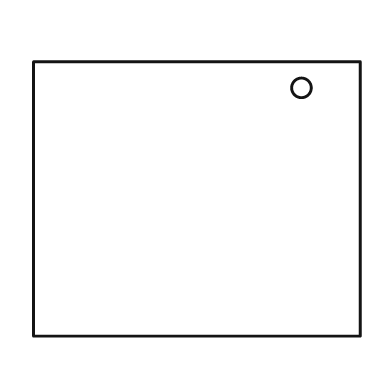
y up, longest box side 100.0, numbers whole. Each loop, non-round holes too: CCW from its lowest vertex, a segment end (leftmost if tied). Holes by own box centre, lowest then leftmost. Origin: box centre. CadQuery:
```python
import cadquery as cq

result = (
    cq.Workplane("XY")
    .moveTo(-50.0, -42.0)
    .lineTo(50.0, -42.0)
    .lineTo(50.0, 42.0)
    .lineTo(-50.0, 42.0)
    .close()
    .moveTo(32.0, 34.0)
    .circle(3.0)
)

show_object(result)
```